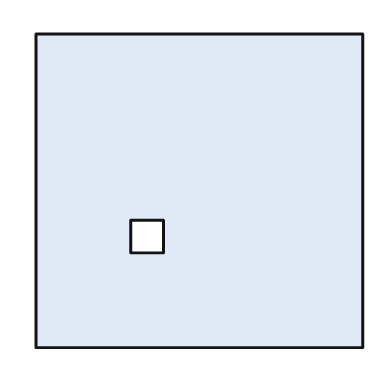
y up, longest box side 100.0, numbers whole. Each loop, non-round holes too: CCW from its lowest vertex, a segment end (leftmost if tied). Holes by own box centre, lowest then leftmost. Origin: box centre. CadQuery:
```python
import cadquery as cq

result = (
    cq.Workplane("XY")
    .moveTo(-50.0, -48.0)
    .lineTo(50.0, -48.0)
    .lineTo(50.0, 48.0)
    .lineTo(-50.0, 48.0)
    .close()
    .moveTo(-21.0, -19.0)
    .lineTo(-11.0, -19.0)
    .lineTo(-11.0, -9.0)
    .lineTo(-21.0, -9.0)
    .close()
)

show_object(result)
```